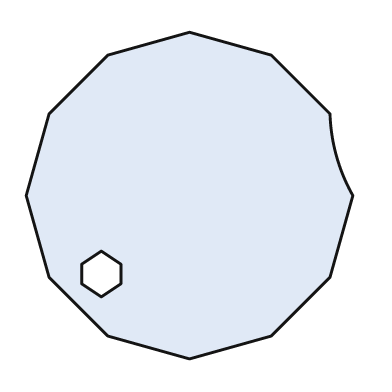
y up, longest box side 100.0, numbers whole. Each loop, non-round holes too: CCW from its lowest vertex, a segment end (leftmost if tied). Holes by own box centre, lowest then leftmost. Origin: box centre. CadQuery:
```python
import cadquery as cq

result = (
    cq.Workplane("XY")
    .moveTo(0.0, -50.0)
    .lineTo(25.0, -43.0)
    .lineTo(43.0, -25.0)
    .lineTo(50.0, 0.0)
    .threePointArc((45.0, 12.0), (43.0, 25.0))
    .lineTo(25.0, 43.0)
    .lineTo(0.0, 50.0)
    .lineTo(-25.0, 43.0)
    .lineTo(-43.0, 25.0)
    .lineTo(-50.0, 0.0)
    .lineTo(-43.0, -25.0)
    .lineTo(-25.0, -43.0)
    .close()
    .moveTo(-27.0, -31.0)
    .lineTo(-21.0, -27.0)
    .lineTo(-21.0, -21.0)
    .lineTo(-27.0, -17.0)
    .lineTo(-33.0, -21.0)
    .lineTo(-33.0, -27.0)
    .close()
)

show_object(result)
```